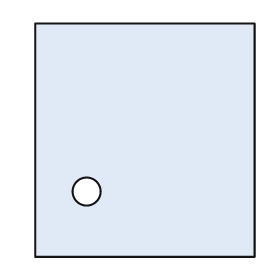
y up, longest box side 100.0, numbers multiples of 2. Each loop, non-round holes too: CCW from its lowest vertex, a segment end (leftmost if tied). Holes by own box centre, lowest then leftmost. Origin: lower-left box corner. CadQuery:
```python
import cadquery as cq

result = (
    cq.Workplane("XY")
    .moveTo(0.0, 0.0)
    .lineTo(94.0, 0.0)
    .lineTo(94.0, 100.0)
    .lineTo(0.0, 100.0)
    .close()
    .moveTo(22.0, 28.0)
    .circle(6.0)
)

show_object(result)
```